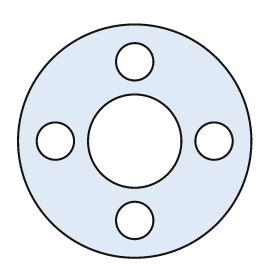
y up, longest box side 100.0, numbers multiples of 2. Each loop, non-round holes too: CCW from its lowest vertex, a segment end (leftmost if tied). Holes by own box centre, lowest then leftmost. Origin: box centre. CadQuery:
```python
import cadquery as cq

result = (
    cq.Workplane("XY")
    .moveTo(0.0, 0.0)
    .circle(50.0)
    .moveTo(0.0, -34.0)
    .circle(8.0)
    .moveTo(-34.0, 0.0)
    .circle(8.0)
    .moveTo(0.0, 0.0)
    .circle(20.0)
    .moveTo(34.0, 0.0)
    .circle(8.0)
    .moveTo(0.0, 34.0)
    .circle(8.0)
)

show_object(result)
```